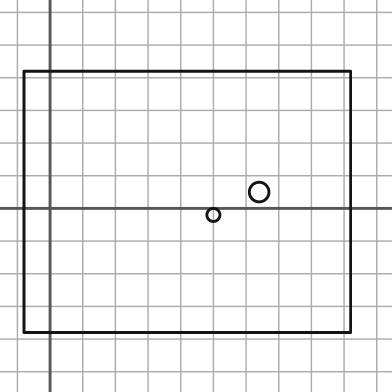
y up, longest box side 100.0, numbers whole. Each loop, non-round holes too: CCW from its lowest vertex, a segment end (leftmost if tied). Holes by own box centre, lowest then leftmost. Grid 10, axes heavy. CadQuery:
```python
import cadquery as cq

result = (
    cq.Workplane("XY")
    .moveTo(-8.0, -38.0)
    .lineTo(92.0, -38.0)
    .lineTo(92.0, 42.0)
    .lineTo(-8.0, 42.0)
    .close()
    .moveTo(50.0, -2.0)
    .circle(2.0)
    .moveTo(64.0, 5.0)
    .circle(3.0)
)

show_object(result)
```